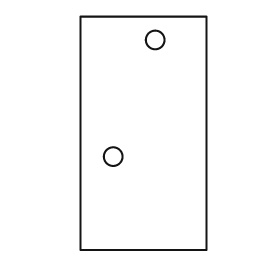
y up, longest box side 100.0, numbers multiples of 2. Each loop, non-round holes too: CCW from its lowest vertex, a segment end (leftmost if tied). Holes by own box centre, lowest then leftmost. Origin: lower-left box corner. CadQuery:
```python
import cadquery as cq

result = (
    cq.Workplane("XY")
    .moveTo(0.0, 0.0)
    .lineTo(54.0, 0.0)
    .lineTo(54.0, 100.0)
    .lineTo(0.0, 100.0)
    .close()
    .moveTo(14.0, 40.0)
    .circle(4.0)
    .moveTo(32.0, 90.0)
    .circle(4.0)
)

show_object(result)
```